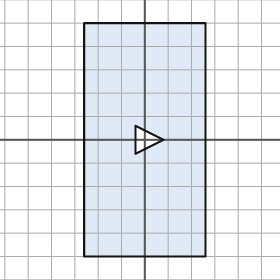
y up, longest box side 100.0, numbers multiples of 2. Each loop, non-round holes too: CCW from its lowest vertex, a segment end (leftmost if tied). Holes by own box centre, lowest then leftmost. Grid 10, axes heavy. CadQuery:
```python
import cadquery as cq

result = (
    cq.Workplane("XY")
    .moveTo(-26.0, -50.0)
    .lineTo(26.0, -50.0)
    .lineTo(26.0, 50.0)
    .lineTo(-26.0, 50.0)
    .close()
    .moveTo(-4.0, -6.0)
    .lineTo(8.0, 0.0)
    .lineTo(-4.0, 6.0)
    .close()
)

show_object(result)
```